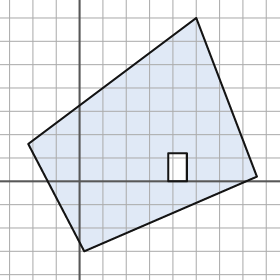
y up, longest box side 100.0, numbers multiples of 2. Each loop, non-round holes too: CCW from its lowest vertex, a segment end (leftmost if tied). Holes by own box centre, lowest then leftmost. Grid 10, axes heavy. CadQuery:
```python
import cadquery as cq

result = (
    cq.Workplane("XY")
    .moveTo(2.0, -30.0)
    .lineTo(76.0, 2.0)
    .lineTo(50.0, 70.0)
    .lineTo(-22.0, 16.0)
    .close()
    .moveTo(38.0, 0.0)
    .lineTo(46.0, 0.0)
    .lineTo(46.0, 12.0)
    .lineTo(38.0, 12.0)
    .close()
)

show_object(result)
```